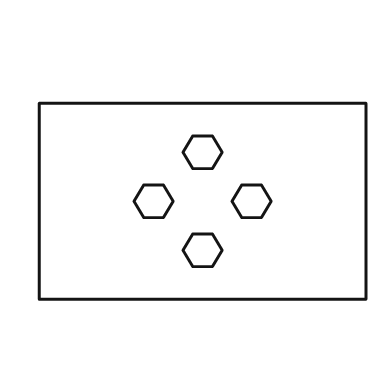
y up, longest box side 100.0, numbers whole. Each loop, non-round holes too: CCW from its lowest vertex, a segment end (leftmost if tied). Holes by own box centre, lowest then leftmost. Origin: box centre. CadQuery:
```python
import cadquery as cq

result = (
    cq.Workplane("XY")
    .moveTo(-50.0, -30.0)
    .lineTo(50.0, -30.0)
    .lineTo(50.0, 30.0)
    .lineTo(-50.0, 30.0)
    .close()
    .moveTo(-3.0, -20.0)
    .lineTo(3.0, -20.0)
    .lineTo(6.0, -15.0)
    .lineTo(3.0, -10.0)
    .lineTo(-3.0, -10.0)
    .lineTo(-6.0, -15.0)
    .close()
    .moveTo(-18.0, -5.0)
    .lineTo(-12.0, -5.0)
    .lineTo(-9.0, 0.0)
    .lineTo(-12.0, 5.0)
    .lineTo(-18.0, 5.0)
    .lineTo(-21.0, 0.0)
    .close()
    .moveTo(12.0, -5.0)
    .lineTo(18.0, -5.0)
    .lineTo(21.0, 0.0)
    .lineTo(18.0, 5.0)
    .lineTo(12.0, 5.0)
    .lineTo(9.0, 0.0)
    .close()
    .moveTo(-3.0, 10.0)
    .lineTo(3.0, 10.0)
    .lineTo(6.0, 15.0)
    .lineTo(3.0, 20.0)
    .lineTo(-3.0, 20.0)
    .lineTo(-6.0, 15.0)
    .close()
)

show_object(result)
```